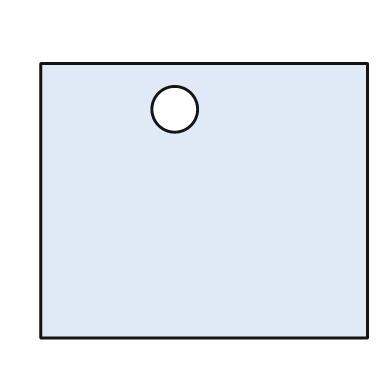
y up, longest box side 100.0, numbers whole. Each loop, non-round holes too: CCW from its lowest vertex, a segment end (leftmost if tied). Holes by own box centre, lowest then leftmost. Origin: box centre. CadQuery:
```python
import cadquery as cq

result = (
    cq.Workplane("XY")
    .moveTo(-50.0, -42.0)
    .lineTo(50.0, -42.0)
    .lineTo(50.0, 42.0)
    .lineTo(-50.0, 42.0)
    .close()
    .moveTo(-9.0, 28.0)
    .circle(7.0)
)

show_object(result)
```